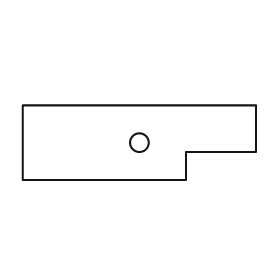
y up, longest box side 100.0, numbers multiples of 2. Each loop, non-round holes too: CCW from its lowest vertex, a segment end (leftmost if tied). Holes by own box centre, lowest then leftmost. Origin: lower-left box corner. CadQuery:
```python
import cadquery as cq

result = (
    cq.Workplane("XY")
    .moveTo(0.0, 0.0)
    .lineTo(70.0, 0.0)
    .lineTo(70.0, 12.0)
    .lineTo(100.0, 12.0)
    .lineTo(100.0, 32.0)
    .lineTo(0.0, 32.0)
    .close()
    .moveTo(50.0, 16.0)
    .circle(4.0)
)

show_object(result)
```